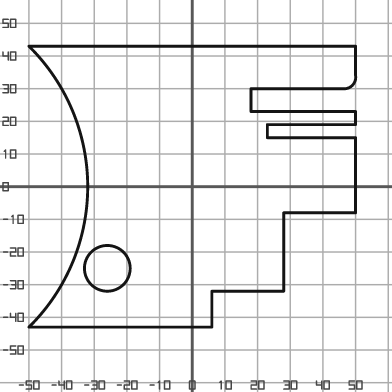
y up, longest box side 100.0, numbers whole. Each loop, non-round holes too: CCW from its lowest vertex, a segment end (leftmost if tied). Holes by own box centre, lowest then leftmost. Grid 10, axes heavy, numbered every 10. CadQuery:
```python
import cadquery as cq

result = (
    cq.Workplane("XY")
    .moveTo(-50.0, -43.0)
    .lineTo(6.0, -43.0)
    .lineTo(6.0, -32.0)
    .lineTo(28.0, -32.0)
    .lineTo(28.0, -8.0)
    .lineTo(50.0, -8.0)
    .lineTo(50.0, 15.0)
    .lineTo(23.0, 15.0)
    .lineTo(23.0, 19.0)
    .lineTo(50.0, 19.0)
    .lineTo(50.0, 23.0)
    .lineTo(18.0, 23.0)
    .lineTo(18.0, 30.0)
    .lineTo(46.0, 30.0)
    .threePointArc((49.0, 31.0), (50.0, 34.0))
    .lineTo(50.0, 43.0)
    .lineTo(-50.0, 43.0)
    .threePointArc((-32.0, 0.0), (-50.0, -43.0))
    .close()
    .moveTo(-26.0, -25.0)
    .circle(7.0)
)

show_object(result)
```